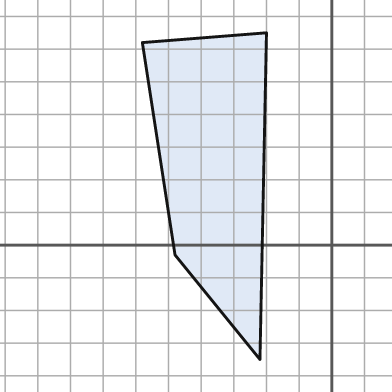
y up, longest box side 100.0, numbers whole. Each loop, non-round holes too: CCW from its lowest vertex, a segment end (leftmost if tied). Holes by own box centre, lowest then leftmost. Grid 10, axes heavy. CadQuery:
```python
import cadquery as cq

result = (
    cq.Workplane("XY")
    .moveTo(-22.0, -35.0)
    .lineTo(-20.0, 65.0)
    .lineTo(-58.0, 62.0)
    .lineTo(-48.0, -3.0)
    .close()
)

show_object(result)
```